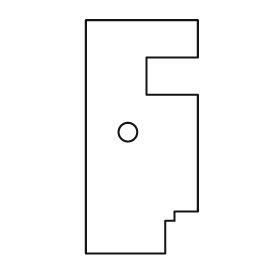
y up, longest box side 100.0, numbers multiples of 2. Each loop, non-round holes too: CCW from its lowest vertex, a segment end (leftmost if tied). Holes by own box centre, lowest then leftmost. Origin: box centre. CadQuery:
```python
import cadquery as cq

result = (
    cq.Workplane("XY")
    .moveTo(-24.0, -50.0)
    .lineTo(10.0, -50.0)
    .lineTo(10.0, -36.0)
    .lineTo(14.0, -36.0)
    .lineTo(14.0, -32.0)
    .lineTo(24.0, -32.0)
    .lineTo(24.0, 18.0)
    .lineTo(2.0, 18.0)
    .lineTo(2.0, 34.0)
    .lineTo(24.0, 34.0)
    .lineTo(24.0, 50.0)
    .lineTo(-24.0, 50.0)
    .close()
    .moveTo(-6.0, 2.0)
    .circle(4.0)
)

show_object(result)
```